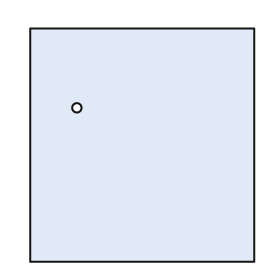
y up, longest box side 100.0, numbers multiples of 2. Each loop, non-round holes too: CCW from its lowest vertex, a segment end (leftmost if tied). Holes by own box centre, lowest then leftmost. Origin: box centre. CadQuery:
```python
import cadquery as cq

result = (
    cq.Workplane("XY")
    .moveTo(-48.0, -50.0)
    .lineTo(48.0, -50.0)
    .lineTo(48.0, 50.0)
    .lineTo(-48.0, 50.0)
    .close()
    .moveTo(-28.0, 16.0)
    .circle(2.0)
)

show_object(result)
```